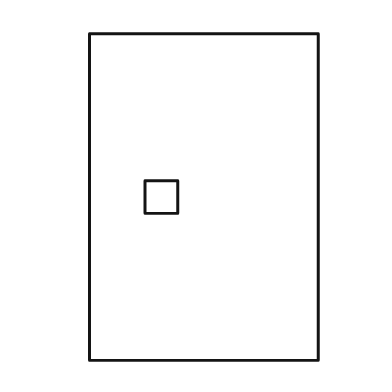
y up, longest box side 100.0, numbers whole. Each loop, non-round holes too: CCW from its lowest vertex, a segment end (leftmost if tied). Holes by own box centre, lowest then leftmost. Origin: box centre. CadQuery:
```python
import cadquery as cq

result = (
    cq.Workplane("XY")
    .moveTo(-35.0, -50.0)
    .lineTo(35.0, -50.0)
    .lineTo(35.0, 50.0)
    .lineTo(-35.0, 50.0)
    .close()
    .moveTo(-18.0, -5.0)
    .lineTo(-8.0, -5.0)
    .lineTo(-8.0, 5.0)
    .lineTo(-18.0, 5.0)
    .close()
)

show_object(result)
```